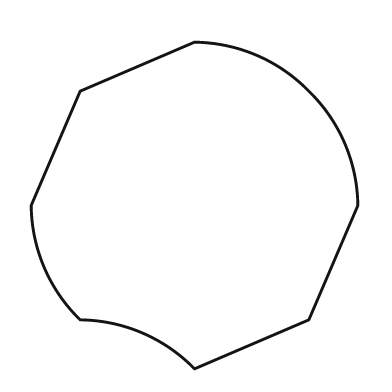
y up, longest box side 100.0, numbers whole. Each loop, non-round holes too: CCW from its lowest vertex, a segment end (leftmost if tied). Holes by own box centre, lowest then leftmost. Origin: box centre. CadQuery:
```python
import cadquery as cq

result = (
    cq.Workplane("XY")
    .moveTo(0.0, -50.0)
    .lineTo(35.0, -35.0)
    .lineTo(50.0, 0.0)
    .threePointArc((46.0, 19.0), (35.0, 35.0))
    .threePointArc((19.0, 46.0), (0.0, 50.0))
    .lineTo(-35.0, 35.0)
    .lineTo(-50.0, 0.0)
    .threePointArc((-46.0, -19.0), (-35.0, -35.0))
    .threePointArc((-16.0, -39.0), (0.0, -50.0))
    .close()
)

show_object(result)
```